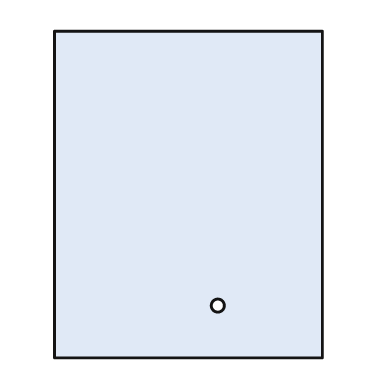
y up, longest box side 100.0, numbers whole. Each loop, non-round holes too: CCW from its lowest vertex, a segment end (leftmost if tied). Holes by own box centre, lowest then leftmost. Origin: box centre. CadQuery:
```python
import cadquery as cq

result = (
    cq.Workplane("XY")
    .moveTo(-41.0, -50.0)
    .lineTo(41.0, -50.0)
    .lineTo(41.0, 50.0)
    .lineTo(-41.0, 50.0)
    .close()
    .moveTo(9.0, -34.0)
    .circle(2.0)
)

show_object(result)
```